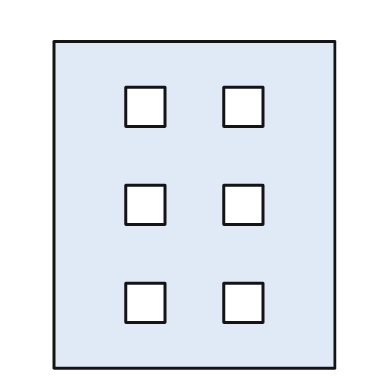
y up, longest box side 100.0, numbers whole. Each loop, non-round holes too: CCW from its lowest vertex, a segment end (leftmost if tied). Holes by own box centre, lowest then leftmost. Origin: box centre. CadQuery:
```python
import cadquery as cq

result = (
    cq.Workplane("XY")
    .moveTo(-43.0, -50.0)
    .lineTo(43.0, -50.0)
    .lineTo(43.0, 50.0)
    .lineTo(-43.0, 50.0)
    .close()
    .moveTo(-21.0, -36.0)
    .lineTo(-9.0, -36.0)
    .lineTo(-9.0, -24.0)
    .lineTo(-21.0, -24.0)
    .close()
    .moveTo(9.0, -36.0)
    .lineTo(21.0, -36.0)
    .lineTo(21.0, -24.0)
    .lineTo(9.0, -24.0)
    .close()
    .moveTo(-21.0, -6.0)
    .lineTo(-9.0, -6.0)
    .lineTo(-9.0, 6.0)
    .lineTo(-21.0, 6.0)
    .close()
    .moveTo(9.0, -6.0)
    .lineTo(21.0, -6.0)
    .lineTo(21.0, 6.0)
    .lineTo(9.0, 6.0)
    .close()
    .moveTo(-21.0, 24.0)
    .lineTo(-9.0, 24.0)
    .lineTo(-9.0, 36.0)
    .lineTo(-21.0, 36.0)
    .close()
    .moveTo(9.0, 24.0)
    .lineTo(21.0, 24.0)
    .lineTo(21.0, 36.0)
    .lineTo(9.0, 36.0)
    .close()
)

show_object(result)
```